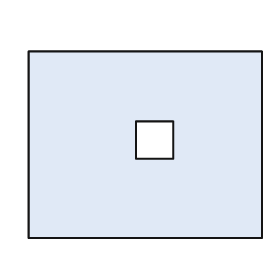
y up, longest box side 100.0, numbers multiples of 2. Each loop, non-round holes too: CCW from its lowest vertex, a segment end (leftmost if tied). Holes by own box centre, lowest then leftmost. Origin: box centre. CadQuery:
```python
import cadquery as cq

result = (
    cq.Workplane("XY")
    .moveTo(-50.0, -40.0)
    .lineTo(50.0, -40.0)
    .lineTo(50.0, 40.0)
    .lineTo(-50.0, 40.0)
    .close()
    .moveTo(-4.0, -6.0)
    .lineTo(12.0, -6.0)
    .lineTo(12.0, 10.0)
    .lineTo(-4.0, 10.0)
    .close()
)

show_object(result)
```